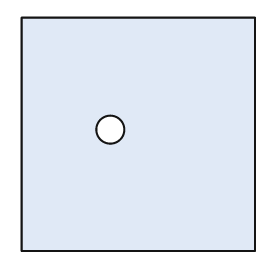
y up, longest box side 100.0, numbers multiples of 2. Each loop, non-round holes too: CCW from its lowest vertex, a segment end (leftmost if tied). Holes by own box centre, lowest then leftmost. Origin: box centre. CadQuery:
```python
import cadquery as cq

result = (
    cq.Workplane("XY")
    .moveTo(-50.0, -50.0)
    .lineTo(50.0, -50.0)
    .lineTo(50.0, 50.0)
    .lineTo(-50.0, 50.0)
    .close()
    .moveTo(-12.0, 2.0)
    .circle(6.0)
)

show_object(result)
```